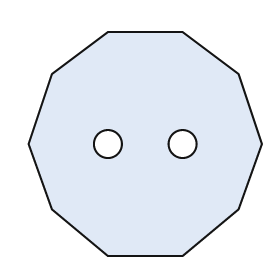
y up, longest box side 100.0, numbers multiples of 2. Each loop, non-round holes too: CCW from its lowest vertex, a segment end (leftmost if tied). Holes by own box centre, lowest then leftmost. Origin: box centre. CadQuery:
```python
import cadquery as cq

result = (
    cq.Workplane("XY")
    .moveTo(-16.0, -48.0)
    .lineTo(16.0, -48.0)
    .lineTo(40.0, -28.0)
    .lineTo(50.0, 0.0)
    .lineTo(40.0, 30.0)
    .lineTo(16.0, 48.0)
    .lineTo(-16.0, 48.0)
    .lineTo(-40.0, 30.0)
    .lineTo(-50.0, 0.0)
    .lineTo(-40.0, -28.0)
    .close()
    .moveTo(-16.0, 0.0)
    .circle(6.0)
    .moveTo(16.0, 0.0)
    .circle(6.0)
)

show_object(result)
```